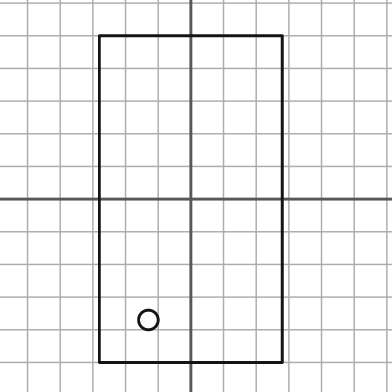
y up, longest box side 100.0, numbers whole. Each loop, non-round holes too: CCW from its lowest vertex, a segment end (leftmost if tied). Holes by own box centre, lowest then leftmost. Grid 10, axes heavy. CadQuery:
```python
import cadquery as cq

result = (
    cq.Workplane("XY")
    .moveTo(-28.0, -50.0)
    .lineTo(28.0, -50.0)
    .lineTo(28.0, 50.0)
    .lineTo(-28.0, 50.0)
    .close()
    .moveTo(-13.0, -37.0)
    .circle(3.0)
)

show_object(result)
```